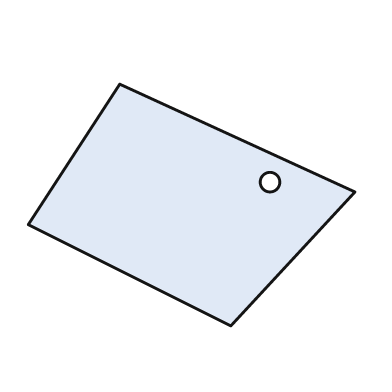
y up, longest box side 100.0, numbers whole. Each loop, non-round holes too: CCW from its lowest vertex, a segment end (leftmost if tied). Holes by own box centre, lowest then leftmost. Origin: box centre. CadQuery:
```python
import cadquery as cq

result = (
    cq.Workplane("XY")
    .moveTo(12.0, -37.0)
    .lineTo(50.0, 4.0)
    .lineTo(-22.0, 37.0)
    .lineTo(-50.0, -6.0)
    .close()
    .moveTo(24.0, 7.0)
    .circle(3.0)
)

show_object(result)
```